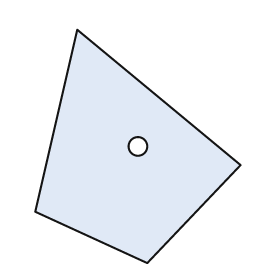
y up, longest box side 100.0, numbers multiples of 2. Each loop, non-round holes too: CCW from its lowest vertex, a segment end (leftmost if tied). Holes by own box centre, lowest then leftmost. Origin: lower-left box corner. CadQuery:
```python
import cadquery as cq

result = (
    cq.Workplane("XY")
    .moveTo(48.0, 0.0)
    .lineTo(88.0, 42.0)
    .lineTo(18.0, 100.0)
    .lineTo(0.0, 22.0)
    .close()
    .moveTo(44.0, 50.0)
    .circle(4.0)
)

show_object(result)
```